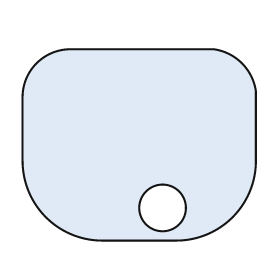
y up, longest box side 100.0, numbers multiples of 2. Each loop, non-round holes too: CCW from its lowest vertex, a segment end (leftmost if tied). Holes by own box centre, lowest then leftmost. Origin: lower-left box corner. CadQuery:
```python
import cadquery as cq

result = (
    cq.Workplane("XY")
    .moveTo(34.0, 0.0)
    .lineTo(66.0, 0.0)
    .threePointArc((90.0, 10.0), (100.0, 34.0))
    .lineTo(100.0, 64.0)
    .threePointArc((94.0, 76.0), (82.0, 82.0))
    .lineTo(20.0, 82.0)
    .threePointArc((6.0, 76.0), (0.0, 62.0))
    .lineTo(0.0, 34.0)
    .threePointArc((10.0, 10.0), (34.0, 0.0))
    .close()
    .moveTo(60.0, 14.0)
    .circle(10.0)
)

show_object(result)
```